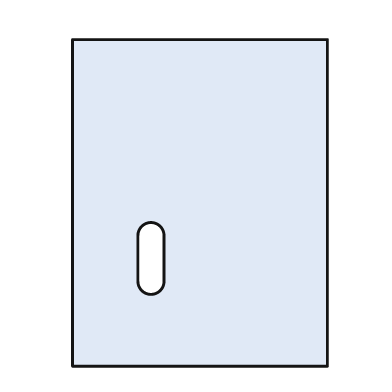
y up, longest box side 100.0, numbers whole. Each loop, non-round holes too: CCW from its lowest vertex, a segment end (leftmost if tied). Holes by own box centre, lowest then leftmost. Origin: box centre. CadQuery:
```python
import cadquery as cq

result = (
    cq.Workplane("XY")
    .moveTo(-39.0, -50.0)
    .lineTo(39.0, -50.0)
    .lineTo(39.0, 50.0)
    .lineTo(-39.0, 50.0)
    .close()
    .moveTo(-19.0, -24.0)
    .threePointArc((-15.0, -28.0), (-11.0, -24.0))
    .lineTo(-11.0, -10.0)
    .threePointArc((-15.0, -6.0), (-19.0, -10.0))
    .close()
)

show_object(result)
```